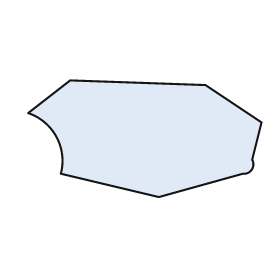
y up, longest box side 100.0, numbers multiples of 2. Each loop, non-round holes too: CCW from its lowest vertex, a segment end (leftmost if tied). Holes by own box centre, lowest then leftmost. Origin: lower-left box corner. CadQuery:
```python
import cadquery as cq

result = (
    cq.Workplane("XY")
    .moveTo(56.0, 0.0)
    .lineTo(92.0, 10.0)
    .threePointArc((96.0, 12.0), (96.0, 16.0))
    .lineTo(100.0, 32.0)
    .lineTo(76.0, 48.0)
    .lineTo(18.0, 50.0)
    .lineTo(0.0, 36.0)
    .threePointArc((12.0, 26.0), (14.0, 10.0))
    .close()
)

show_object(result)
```